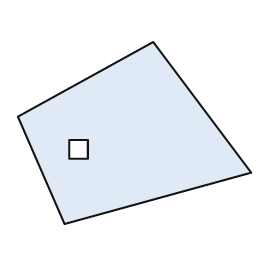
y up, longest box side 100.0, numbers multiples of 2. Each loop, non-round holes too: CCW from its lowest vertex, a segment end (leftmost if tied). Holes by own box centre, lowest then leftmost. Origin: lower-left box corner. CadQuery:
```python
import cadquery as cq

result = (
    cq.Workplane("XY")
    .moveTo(20.0, 0.0)
    .lineTo(100.0, 22.0)
    .lineTo(58.0, 78.0)
    .lineTo(0.0, 46.0)
    .close()
    .moveTo(22.0, 28.0)
    .lineTo(30.0, 28.0)
    .lineTo(30.0, 36.0)
    .lineTo(22.0, 36.0)
    .close()
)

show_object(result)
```